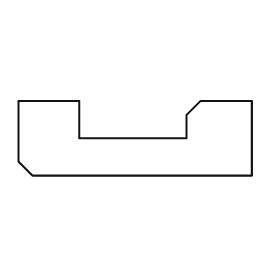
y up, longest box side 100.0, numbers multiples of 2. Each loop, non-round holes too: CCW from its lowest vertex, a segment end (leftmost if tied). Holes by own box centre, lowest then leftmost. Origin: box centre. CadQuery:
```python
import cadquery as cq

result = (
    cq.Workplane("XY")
    .moveTo(-44.0, -16.0)
    .lineTo(50.0, -16.0)
    .lineTo(50.0, 16.0)
    .lineTo(28.0, 16.0)
    .lineTo(22.0, 10.0)
    .lineTo(22.0, 0.0)
    .lineTo(-24.0, 0.0)
    .lineTo(-24.0, 16.0)
    .lineTo(-50.0, 16.0)
    .lineTo(-50.0, -10.0)
    .close()
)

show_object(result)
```